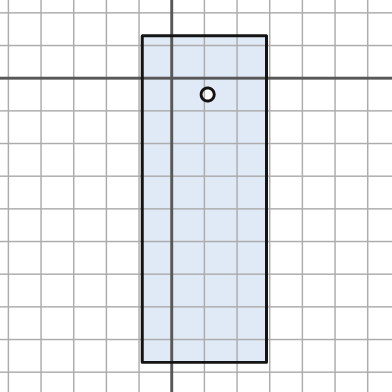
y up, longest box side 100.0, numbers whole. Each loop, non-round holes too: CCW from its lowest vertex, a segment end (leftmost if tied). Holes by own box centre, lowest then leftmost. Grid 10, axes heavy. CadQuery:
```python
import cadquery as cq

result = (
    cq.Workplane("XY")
    .moveTo(-9.0, -87.0)
    .lineTo(29.0, -87.0)
    .lineTo(29.0, 13.0)
    .lineTo(-9.0, 13.0)
    .close()
    .moveTo(11.0, -5.0)
    .circle(2.0)
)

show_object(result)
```